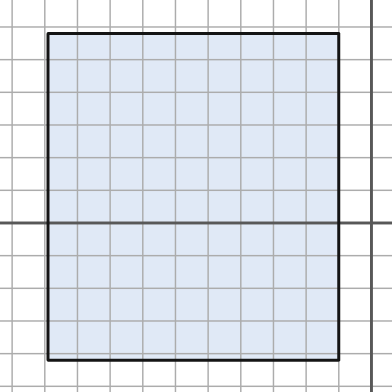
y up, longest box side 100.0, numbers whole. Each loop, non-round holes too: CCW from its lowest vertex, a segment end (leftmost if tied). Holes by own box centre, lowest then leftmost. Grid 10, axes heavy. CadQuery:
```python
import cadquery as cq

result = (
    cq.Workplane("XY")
    .moveTo(-99.0, -42.0)
    .lineTo(-10.0, -42.0)
    .lineTo(-10.0, 58.0)
    .lineTo(-99.0, 58.0)
    .close()
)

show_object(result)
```